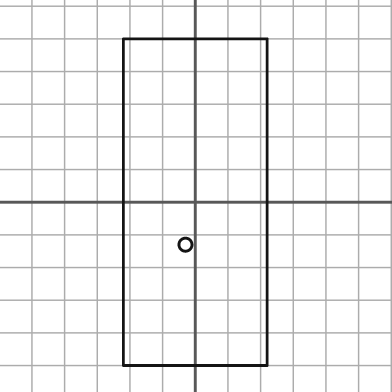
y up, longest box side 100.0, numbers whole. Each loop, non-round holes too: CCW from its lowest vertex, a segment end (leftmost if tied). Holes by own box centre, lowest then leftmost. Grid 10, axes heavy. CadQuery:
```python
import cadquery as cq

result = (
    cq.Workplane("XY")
    .moveTo(-22.0, -50.0)
    .lineTo(22.0, -50.0)
    .lineTo(22.0, 50.0)
    .lineTo(-22.0, 50.0)
    .close()
    .moveTo(-3.0, -13.0)
    .circle(2.0)
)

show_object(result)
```